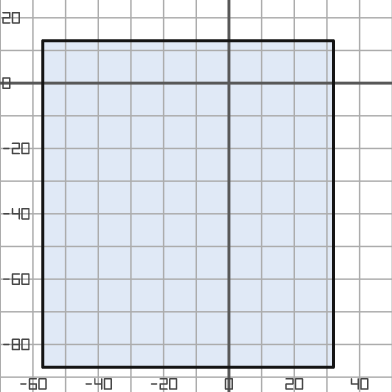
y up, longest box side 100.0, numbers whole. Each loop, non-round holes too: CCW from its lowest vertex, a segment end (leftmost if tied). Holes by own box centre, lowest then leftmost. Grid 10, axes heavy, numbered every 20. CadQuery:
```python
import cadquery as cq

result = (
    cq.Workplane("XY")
    .moveTo(-57.0, -87.0)
    .lineTo(32.0, -87.0)
    .lineTo(32.0, 13.0)
    .lineTo(-57.0, 13.0)
    .close()
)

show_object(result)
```